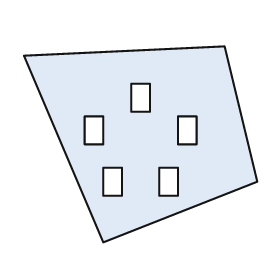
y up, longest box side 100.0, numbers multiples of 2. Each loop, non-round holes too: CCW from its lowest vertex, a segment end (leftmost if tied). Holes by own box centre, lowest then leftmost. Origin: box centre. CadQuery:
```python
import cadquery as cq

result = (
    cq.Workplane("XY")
    .moveTo(-16.0, -42.0)
    .lineTo(50.0, -16.0)
    .lineTo(36.0, 42.0)
    .lineTo(-50.0, 38.0)
    .close()
    .moveTo(-16.0, -22.0)
    .lineTo(-8.0, -22.0)
    .lineTo(-8.0, -10.0)
    .lineTo(-16.0, -10.0)
    .close()
    .moveTo(8.0, -22.0)
    .lineTo(16.0, -22.0)
    .lineTo(16.0, -10.0)
    .lineTo(8.0, -10.0)
    .close()
    .moveTo(-24.0, 0.0)
    .lineTo(-16.0, 0.0)
    .lineTo(-16.0, 12.0)
    .lineTo(-24.0, 12.0)
    .close()
    .moveTo(16.0, 0.0)
    .lineTo(24.0, 0.0)
    .lineTo(24.0, 12.0)
    .lineTo(16.0, 12.0)
    .close()
    .moveTo(-4.0, 14.0)
    .lineTo(4.0, 14.0)
    .lineTo(4.0, 26.0)
    .lineTo(-4.0, 26.0)
    .close()
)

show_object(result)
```